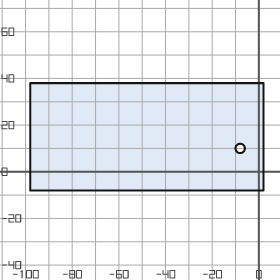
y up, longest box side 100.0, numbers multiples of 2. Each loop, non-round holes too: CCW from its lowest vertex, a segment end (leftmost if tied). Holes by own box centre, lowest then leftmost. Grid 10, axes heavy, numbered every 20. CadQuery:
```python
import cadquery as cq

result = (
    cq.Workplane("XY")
    .moveTo(-98.0, -8.0)
    .lineTo(2.0, -8.0)
    .lineTo(2.0, 38.0)
    .lineTo(-98.0, 38.0)
    .close()
    .moveTo(-8.0, 10.0)
    .circle(2.0)
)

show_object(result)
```